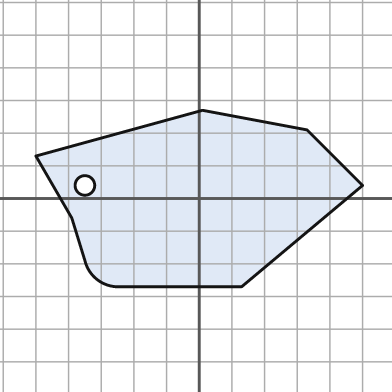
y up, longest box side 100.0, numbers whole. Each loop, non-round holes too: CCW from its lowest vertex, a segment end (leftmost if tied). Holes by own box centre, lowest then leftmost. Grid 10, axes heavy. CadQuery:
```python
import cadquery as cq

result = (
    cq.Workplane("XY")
    .moveTo(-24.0, -27.0)
    .lineTo(13.0, -27.0)
    .lineTo(50.0, 4.0)
    .lineTo(33.0, 21.0)
    .lineTo(1.0, 27.0)
    .lineTo(-50.0, 13.0)
    .lineTo(-39.0, -6.0)
    .lineTo(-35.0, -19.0)
    .threePointArc((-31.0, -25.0), (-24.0, -27.0))
    .close()
    .moveTo(-35.0, 4.0)
    .circle(3.0)
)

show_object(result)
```